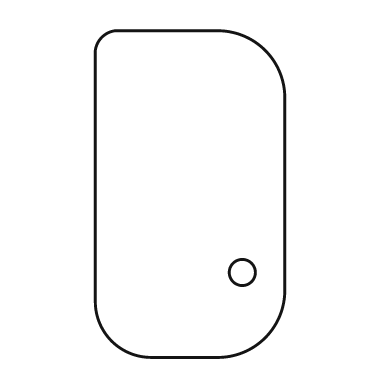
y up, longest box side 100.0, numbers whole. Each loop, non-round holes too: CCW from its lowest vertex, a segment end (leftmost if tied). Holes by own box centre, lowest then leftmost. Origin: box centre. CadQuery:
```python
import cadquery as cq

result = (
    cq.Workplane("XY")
    .moveTo(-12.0, -50.0)
    .lineTo(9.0, -50.0)
    .threePointArc((23.0, -44.0), (29.0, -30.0))
    .lineTo(29.0, 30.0)
    .threePointArc((23.0, 44.0), (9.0, 50.0))
    .lineTo(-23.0, 50.0)
    .threePointArc((-27.0, 48.0), (-29.0, 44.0))
    .lineTo(-29.0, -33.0)
    .threePointArc((-24.0, -45.0), (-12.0, -50.0))
    .close()
    .moveTo(16.0, -24.0)
    .circle(4.0)
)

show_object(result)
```